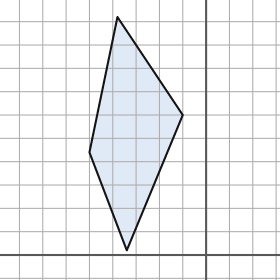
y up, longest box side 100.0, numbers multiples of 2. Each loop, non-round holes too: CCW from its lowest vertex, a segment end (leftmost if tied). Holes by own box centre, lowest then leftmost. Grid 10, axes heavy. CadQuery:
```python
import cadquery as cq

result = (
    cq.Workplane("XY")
    .moveTo(-34.0, 2.0)
    .lineTo(-10.0, 60.0)
    .lineTo(-38.0, 102.0)
    .lineTo(-50.0, 44.0)
    .close()
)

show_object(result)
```